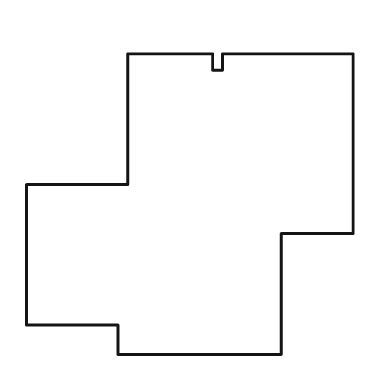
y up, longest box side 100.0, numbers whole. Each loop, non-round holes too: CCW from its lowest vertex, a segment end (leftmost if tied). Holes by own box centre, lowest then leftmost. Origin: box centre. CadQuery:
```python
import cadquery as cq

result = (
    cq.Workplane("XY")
    .moveTo(-22.0, -46.0)
    .lineTo(28.0, -46.0)
    .lineTo(28.0, -9.0)
    .lineTo(50.0, -9.0)
    .lineTo(50.0, 46.0)
    .lineTo(10.0, 46.0)
    .lineTo(10.0, 41.0)
    .lineTo(7.0, 41.0)
    .lineTo(7.0, 46.0)
    .lineTo(-19.0, 46.0)
    .lineTo(-19.0, 6.0)
    .lineTo(-50.0, 6.0)
    .lineTo(-50.0, -37.0)
    .lineTo(-22.0, -37.0)
    .close()
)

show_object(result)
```